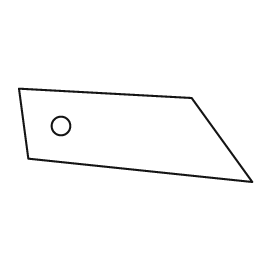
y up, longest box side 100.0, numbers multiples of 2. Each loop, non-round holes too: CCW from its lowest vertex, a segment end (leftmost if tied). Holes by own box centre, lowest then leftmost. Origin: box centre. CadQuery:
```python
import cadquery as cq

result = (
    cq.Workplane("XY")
    .moveTo(50.0, -20.0)
    .lineTo(24.0, 16.0)
    .lineTo(-50.0, 20.0)
    .lineTo(-46.0, -10.0)
    .close()
    .moveTo(-32.0, 4.0)
    .circle(4.0)
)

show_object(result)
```